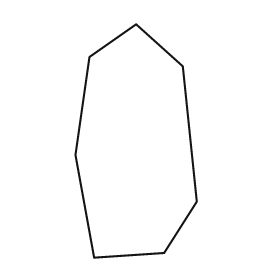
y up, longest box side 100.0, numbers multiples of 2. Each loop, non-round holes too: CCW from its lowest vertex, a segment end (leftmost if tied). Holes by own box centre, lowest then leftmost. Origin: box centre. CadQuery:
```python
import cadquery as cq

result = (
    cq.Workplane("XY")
    .moveTo(-18.0, -50.0)
    .lineTo(12.0, -48.0)
    .lineTo(26.0, -26.0)
    .lineTo(20.0, 32.0)
    .lineTo(0.0, 50.0)
    .lineTo(-20.0, 36.0)
    .lineTo(-26.0, -6.0)
    .close()
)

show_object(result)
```